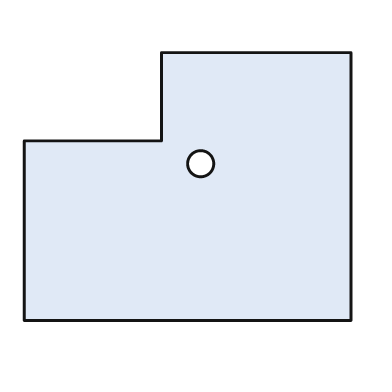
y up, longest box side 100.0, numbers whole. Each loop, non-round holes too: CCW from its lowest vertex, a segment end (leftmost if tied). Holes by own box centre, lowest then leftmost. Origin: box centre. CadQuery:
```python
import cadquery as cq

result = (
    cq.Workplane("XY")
    .moveTo(-50.0, -41.0)
    .lineTo(50.0, -41.0)
    .lineTo(50.0, 41.0)
    .lineTo(-8.0, 41.0)
    .lineTo(-8.0, 14.0)
    .lineTo(-50.0, 14.0)
    .close()
    .moveTo(4.0, 7.0)
    .circle(4.0)
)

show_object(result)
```